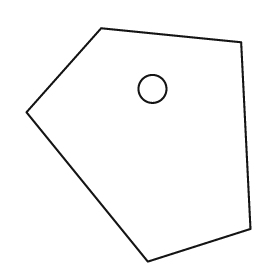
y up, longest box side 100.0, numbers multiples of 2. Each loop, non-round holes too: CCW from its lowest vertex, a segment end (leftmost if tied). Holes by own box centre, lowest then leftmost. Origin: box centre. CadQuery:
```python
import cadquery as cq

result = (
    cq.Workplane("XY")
    .moveTo(4.0, -50.0)
    .lineTo(48.0, -36.0)
    .lineTo(44.0, 44.0)
    .lineTo(-16.0, 50.0)
    .lineTo(-48.0, 14.0)
    .close()
    .moveTo(6.0, 24.0)
    .circle(6.0)
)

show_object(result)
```